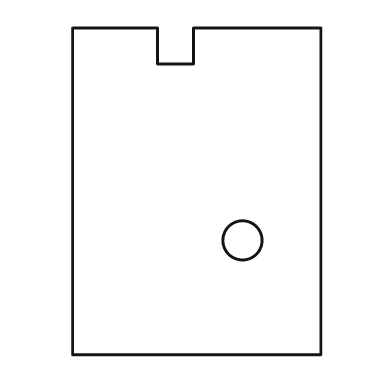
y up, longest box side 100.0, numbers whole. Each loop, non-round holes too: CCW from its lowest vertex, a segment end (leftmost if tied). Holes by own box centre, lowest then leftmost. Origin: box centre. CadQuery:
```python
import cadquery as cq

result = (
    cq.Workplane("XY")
    .moveTo(-38.0, -50.0)
    .lineTo(38.0, -50.0)
    .lineTo(38.0, 50.0)
    .lineTo(-1.0, 50.0)
    .lineTo(-1.0, 39.0)
    .lineTo(-12.0, 39.0)
    .lineTo(-12.0, 50.0)
    .lineTo(-38.0, 50.0)
    .close()
    .moveTo(14.0, -15.0)
    .circle(6.0)
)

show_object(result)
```